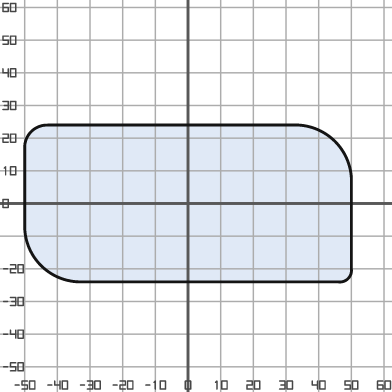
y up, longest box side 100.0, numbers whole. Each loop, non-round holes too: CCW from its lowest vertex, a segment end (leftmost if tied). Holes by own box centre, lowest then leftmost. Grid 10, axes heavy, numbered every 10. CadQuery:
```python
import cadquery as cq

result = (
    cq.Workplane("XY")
    .moveTo(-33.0, -24.0)
    .lineTo(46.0, -24.0)
    .threePointArc((49.0, -23.0), (50.0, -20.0))
    .lineTo(50.0, 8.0)
    .threePointArc((45.0, 19.0), (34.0, 24.0))
    .lineTo(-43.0, 24.0)
    .threePointArc((-48.0, 22.0), (-50.0, 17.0))
    .lineTo(-50.0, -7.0)
    .threePointArc((-45.0, -19.0), (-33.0, -24.0))
    .close()
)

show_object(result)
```